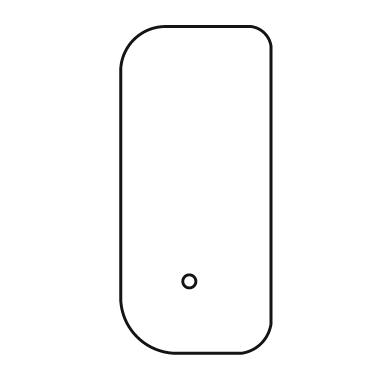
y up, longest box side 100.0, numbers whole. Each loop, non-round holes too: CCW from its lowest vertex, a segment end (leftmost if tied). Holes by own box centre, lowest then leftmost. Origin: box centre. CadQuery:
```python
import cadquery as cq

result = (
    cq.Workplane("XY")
    .moveTo(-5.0, -50.0)
    .lineTo(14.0, -50.0)
    .threePointArc((20.0, -47.0), (23.0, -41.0))
    .lineTo(23.0, 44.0)
    .threePointArc((21.0, 48.0), (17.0, 50.0))
    .lineTo(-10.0, 50.0)
    .threePointArc((-19.0, 46.0), (-23.0, 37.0))
    .lineTo(-23.0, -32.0)
    .threePointArc((-18.0, -45.0), (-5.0, -50.0))
    .close()
    .moveTo(-2.0, -28.0)
    .circle(2.0)
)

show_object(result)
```